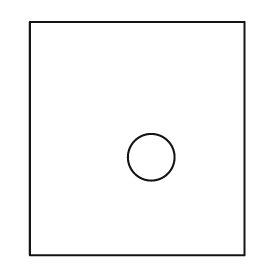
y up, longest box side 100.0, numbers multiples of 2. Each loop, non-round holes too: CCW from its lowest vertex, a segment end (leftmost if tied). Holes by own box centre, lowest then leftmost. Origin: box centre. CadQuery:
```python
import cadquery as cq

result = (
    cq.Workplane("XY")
    .moveTo(-46.0, -50.0)
    .lineTo(46.0, -50.0)
    .lineTo(46.0, 50.0)
    .lineTo(-46.0, 50.0)
    .close()
    .moveTo(6.0, -8.0)
    .circle(10.0)
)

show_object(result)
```